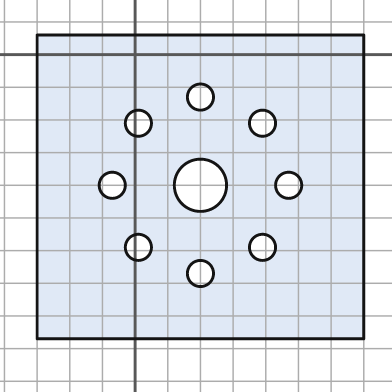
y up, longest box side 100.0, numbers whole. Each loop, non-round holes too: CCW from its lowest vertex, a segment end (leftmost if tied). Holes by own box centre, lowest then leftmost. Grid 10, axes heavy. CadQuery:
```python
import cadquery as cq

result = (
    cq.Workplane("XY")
    .moveTo(-30.0, -87.0)
    .lineTo(70.0, -87.0)
    .lineTo(70.0, 6.0)
    .lineTo(-30.0, 6.0)
    .close()
    .moveTo(20.0, -67.0)
    .circle(4.0)
    .moveTo(1.0, -59.0)
    .circle(4.0)
    .moveTo(39.0, -59.0)
    .circle(4.0)
    .moveTo(-7.0, -40.0)
    .circle(4.0)
    .moveTo(20.0, -40.0)
    .circle(8.0)
    .moveTo(47.0, -40.0)
    .circle(4.0)
    .moveTo(1.0, -21.0)
    .circle(4.0)
    .moveTo(39.0, -21.0)
    .circle(4.0)
    .moveTo(20.0, -13.0)
    .circle(4.0)
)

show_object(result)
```